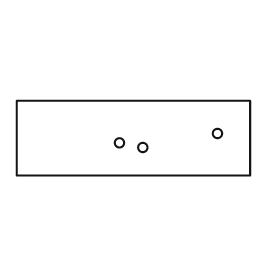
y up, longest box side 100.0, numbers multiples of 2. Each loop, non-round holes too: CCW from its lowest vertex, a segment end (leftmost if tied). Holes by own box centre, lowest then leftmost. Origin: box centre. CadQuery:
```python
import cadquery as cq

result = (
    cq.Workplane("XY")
    .moveTo(-50.0, -16.0)
    .lineTo(50.0, -16.0)
    .lineTo(50.0, 16.0)
    .lineTo(-50.0, 16.0)
    .close()
    .moveTo(4.0, -4.0)
    .circle(2.0)
    .moveTo(-6.0, -2.0)
    .circle(2.0)
    .moveTo(36.0, 2.0)
    .circle(2.0)
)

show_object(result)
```